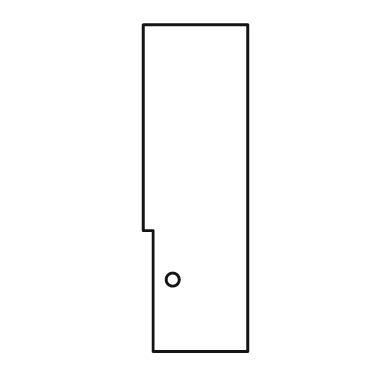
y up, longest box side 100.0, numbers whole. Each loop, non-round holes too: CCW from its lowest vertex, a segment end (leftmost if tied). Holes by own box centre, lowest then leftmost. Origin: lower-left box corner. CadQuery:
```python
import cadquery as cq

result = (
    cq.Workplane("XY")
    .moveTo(3.0, 0.0)
    .lineTo(32.0, 0.0)
    .lineTo(32.0, 100.0)
    .lineTo(0.0, 100.0)
    .lineTo(0.0, 37.0)
    .lineTo(3.0, 37.0)
    .close()
    .moveTo(9.0, 22.0)
    .circle(2.0)
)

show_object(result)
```